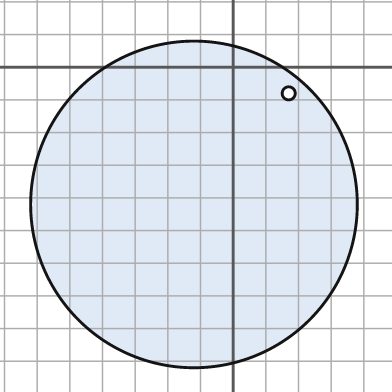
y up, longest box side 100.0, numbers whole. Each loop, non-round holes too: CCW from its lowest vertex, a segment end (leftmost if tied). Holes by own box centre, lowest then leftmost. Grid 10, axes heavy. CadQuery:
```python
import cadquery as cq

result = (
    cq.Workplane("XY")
    .moveTo(-12.0, -42.0)
    .circle(50.0)
    .moveTo(17.0, -8.0)
    .circle(2.0)
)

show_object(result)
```